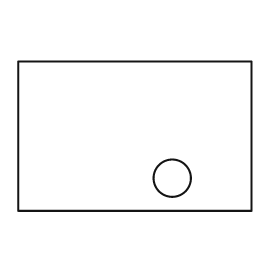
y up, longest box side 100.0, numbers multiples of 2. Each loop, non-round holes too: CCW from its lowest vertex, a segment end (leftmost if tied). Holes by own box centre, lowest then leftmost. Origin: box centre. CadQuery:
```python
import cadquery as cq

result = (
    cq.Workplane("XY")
    .moveTo(-50.0, -32.0)
    .lineTo(50.0, -32.0)
    .lineTo(50.0, 32.0)
    .lineTo(-50.0, 32.0)
    .close()
    .moveTo(16.0, -18.0)
    .circle(8.0)
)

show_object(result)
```